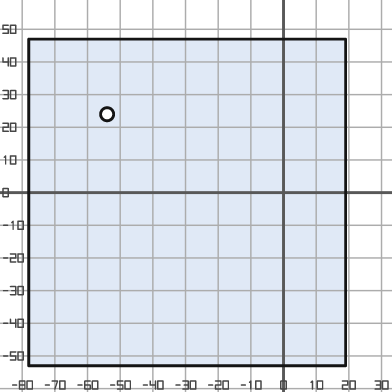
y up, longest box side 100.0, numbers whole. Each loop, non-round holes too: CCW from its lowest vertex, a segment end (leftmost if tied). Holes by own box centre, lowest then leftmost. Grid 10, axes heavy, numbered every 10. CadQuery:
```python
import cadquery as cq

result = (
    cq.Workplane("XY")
    .moveTo(-78.0, -53.0)
    .lineTo(19.0, -53.0)
    .lineTo(19.0, 47.0)
    .lineTo(-78.0, 47.0)
    .close()
    .moveTo(-54.0, 24.0)
    .circle(2.0)
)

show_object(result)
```